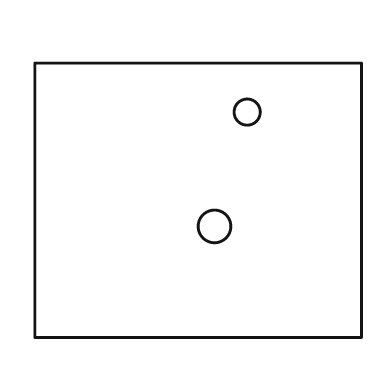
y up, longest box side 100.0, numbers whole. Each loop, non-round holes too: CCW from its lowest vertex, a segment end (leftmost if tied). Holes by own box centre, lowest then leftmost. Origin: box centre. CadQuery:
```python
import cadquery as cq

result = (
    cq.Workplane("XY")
    .moveTo(-50.0, -42.0)
    .lineTo(50.0, -42.0)
    .lineTo(50.0, 42.0)
    .lineTo(-50.0, 42.0)
    .close()
    .moveTo(5.0, -8.0)
    .circle(5.0)
    .moveTo(15.0, 27.0)
    .circle(4.0)
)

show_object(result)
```